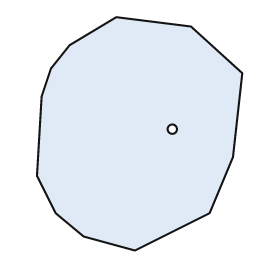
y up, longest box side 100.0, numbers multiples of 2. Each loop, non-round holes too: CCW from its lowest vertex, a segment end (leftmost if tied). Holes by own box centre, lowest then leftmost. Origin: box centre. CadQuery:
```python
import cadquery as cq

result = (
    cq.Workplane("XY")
    .moveTo(-2.0, -50.0)
    .lineTo(30.0, -34.0)
    .lineTo(40.0, -10.0)
    .lineTo(44.0, 26.0)
    .lineTo(22.0, 46.0)
    .lineTo(-10.0, 50.0)
    .lineTo(-30.0, 38.0)
    .lineTo(-38.0, 28.0)
    .lineTo(-42.0, 16.0)
    .lineTo(-44.0, -18.0)
    .lineTo(-36.0, -34.0)
    .lineTo(-24.0, -44.0)
    .close()
    .moveTo(14.0, 2.0)
    .circle(2.0)
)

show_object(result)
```